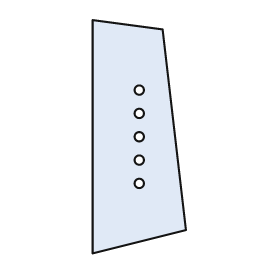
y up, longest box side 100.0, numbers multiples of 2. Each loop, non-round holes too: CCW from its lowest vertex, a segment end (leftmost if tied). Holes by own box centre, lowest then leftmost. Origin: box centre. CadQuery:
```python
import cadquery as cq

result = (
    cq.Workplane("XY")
    .moveTo(-20.0, -50.0)
    .lineTo(20.0, -40.0)
    .lineTo(10.0, 46.0)
    .lineTo(-20.0, 50.0)
    .close()
    .moveTo(0.0, -20.0)
    .circle(2.0)
    .moveTo(0.0, -10.0)
    .circle(2.0)
    .moveTo(0.0, 0.0)
    .circle(2.0)
    .moveTo(0.0, 10.0)
    .circle(2.0)
    .moveTo(0.0, 20.0)
    .circle(2.0)
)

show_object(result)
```